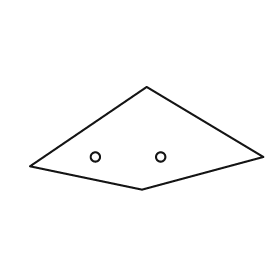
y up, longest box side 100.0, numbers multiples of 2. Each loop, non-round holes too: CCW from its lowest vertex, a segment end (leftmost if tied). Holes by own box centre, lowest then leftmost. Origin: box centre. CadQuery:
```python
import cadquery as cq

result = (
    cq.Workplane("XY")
    .moveTo(-2.0, -22.0)
    .lineTo(50.0, -8.0)
    .lineTo(0.0, 22.0)
    .lineTo(-50.0, -12.0)
    .close()
    .moveTo(-22.0, -8.0)
    .circle(2.0)
    .moveTo(6.0, -8.0)
    .circle(2.0)
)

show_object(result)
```